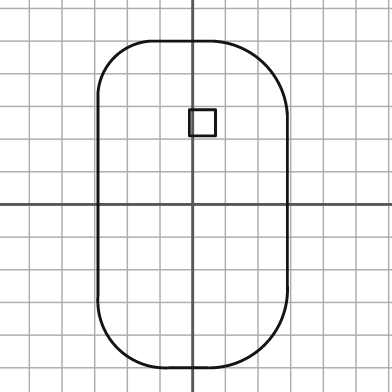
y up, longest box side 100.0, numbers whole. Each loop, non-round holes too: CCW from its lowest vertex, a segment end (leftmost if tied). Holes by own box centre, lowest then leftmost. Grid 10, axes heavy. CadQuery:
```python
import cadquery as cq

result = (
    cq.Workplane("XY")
    .moveTo(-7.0, -50.0)
    .lineTo(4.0, -50.0)
    .threePointArc((22.0, -43.0), (29.0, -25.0))
    .lineTo(29.0, 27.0)
    .threePointArc((22.0, 43.0), (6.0, 50.0))
    .lineTo(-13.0, 50.0)
    .threePointArc((-24.0, 45.0), (-29.0, 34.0))
    .lineTo(-29.0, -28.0)
    .threePointArc((-23.0, -44.0), (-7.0, -50.0))
    .close()
    .moveTo(-1.0, 21.0)
    .lineTo(7.0, 21.0)
    .lineTo(7.0, 29.0)
    .lineTo(-1.0, 29.0)
    .close()
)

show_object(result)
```